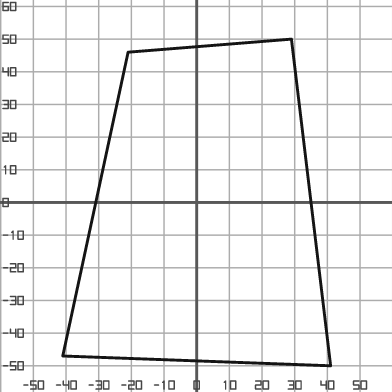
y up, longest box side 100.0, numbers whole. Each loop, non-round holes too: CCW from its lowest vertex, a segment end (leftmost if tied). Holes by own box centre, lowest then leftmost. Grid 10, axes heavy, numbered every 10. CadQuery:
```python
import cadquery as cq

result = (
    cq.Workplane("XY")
    .moveTo(41.0, -50.0)
    .lineTo(29.0, 50.0)
    .lineTo(-21.0, 46.0)
    .lineTo(-41.0, -47.0)
    .close()
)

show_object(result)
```